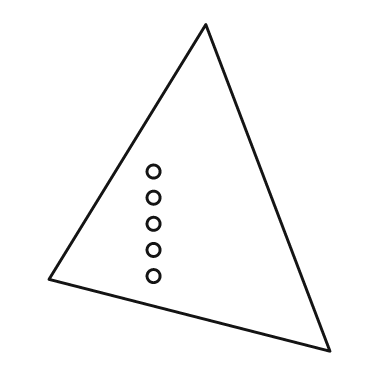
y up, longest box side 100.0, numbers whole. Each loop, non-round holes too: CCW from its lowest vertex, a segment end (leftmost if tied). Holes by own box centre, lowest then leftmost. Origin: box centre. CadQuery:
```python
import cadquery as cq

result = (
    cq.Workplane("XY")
    .moveTo(43.0, -50.0)
    .lineTo(5.0, 50.0)
    .lineTo(-43.0, -28.0)
    .close()
    .moveTo(-11.0, -27.0)
    .circle(2.0)
    .moveTo(-11.0, -19.0)
    .circle(2.0)
    .moveTo(-11.0, -11.0)
    .circle(2.0)
    .moveTo(-11.0, -3.0)
    .circle(2.0)
    .moveTo(-11.0, 5.0)
    .circle(2.0)
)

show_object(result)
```